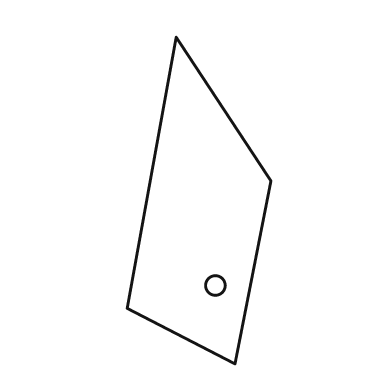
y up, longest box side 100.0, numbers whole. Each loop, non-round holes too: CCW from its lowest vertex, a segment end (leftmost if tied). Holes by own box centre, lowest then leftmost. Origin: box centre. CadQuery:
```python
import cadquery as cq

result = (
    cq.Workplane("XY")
    .moveTo(11.0, -50.0)
    .lineTo(22.0, 6.0)
    .lineTo(-7.0, 50.0)
    .lineTo(-22.0, -33.0)
    .close()
    .moveTo(5.0, -26.0)
    .circle(3.0)
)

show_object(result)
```